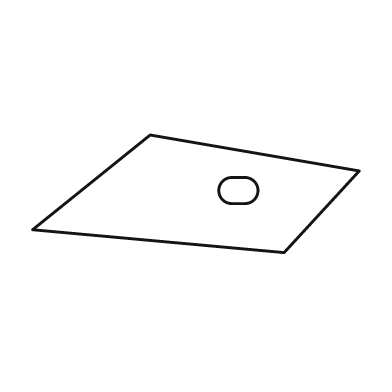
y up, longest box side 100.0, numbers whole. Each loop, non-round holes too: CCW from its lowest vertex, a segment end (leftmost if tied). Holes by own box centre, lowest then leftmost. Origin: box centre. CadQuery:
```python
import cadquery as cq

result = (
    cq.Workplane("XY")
    .moveTo(27.0, -18.0)
    .lineTo(50.0, 7.0)
    .lineTo(-14.0, 18.0)
    .lineTo(-50.0, -11.0)
    .close()
    .moveTo(11.0, -3.0)
    .lineTo(15.0, -3.0)
    .threePointArc((19.0, 1.0), (15.0, 5.0))
    .lineTo(11.0, 5.0)
    .threePointArc((7.0, 1.0), (11.0, -3.0))
    .close()
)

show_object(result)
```